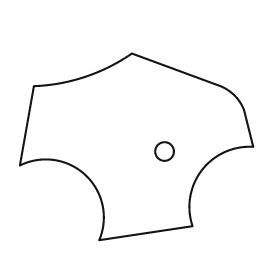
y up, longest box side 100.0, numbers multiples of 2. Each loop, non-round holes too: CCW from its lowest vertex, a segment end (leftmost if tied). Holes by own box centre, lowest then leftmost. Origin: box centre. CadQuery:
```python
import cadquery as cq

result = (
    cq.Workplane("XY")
    .moveTo(-16.0, -40.0)
    .lineTo(24.0, -34.0)
    .threePointArc((28.0, -10.0), (50.0, 0.0))
    .lineTo(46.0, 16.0)
    .threePointArc((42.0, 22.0), (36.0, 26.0))
    .lineTo(-2.0, 40.0)
    .threePointArc((-22.0, 30.0), (-44.0, 26.0))
    .lineTo(-50.0, -8.0)
    .threePointArc((-22.0, -12.0), (-16.0, -40.0))
    .close()
    .moveTo(12.0, -2.0)
    .circle(4.0)
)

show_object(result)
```